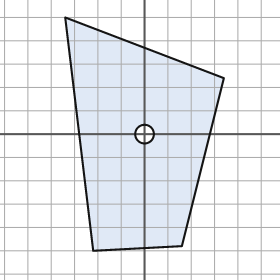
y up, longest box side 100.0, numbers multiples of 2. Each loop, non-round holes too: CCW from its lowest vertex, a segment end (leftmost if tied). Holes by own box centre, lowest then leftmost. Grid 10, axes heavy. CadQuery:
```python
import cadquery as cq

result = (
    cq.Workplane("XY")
    .moveTo(-22.0, -50.0)
    .lineTo(16.0, -48.0)
    .lineTo(34.0, 24.0)
    .lineTo(-34.0, 50.0)
    .close()
    .moveTo(0.0, 0.0)
    .circle(4.0)
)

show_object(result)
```